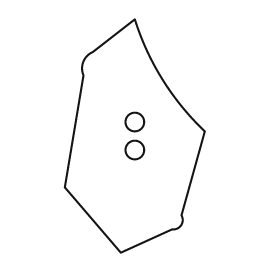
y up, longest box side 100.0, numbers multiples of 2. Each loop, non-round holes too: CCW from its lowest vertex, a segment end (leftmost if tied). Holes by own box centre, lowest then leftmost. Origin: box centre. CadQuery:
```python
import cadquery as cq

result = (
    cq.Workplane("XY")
    .moveTo(-6.0, -50.0)
    .lineTo(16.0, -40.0)
    .threePointArc((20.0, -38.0), (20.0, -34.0))
    .lineTo(30.0, 2.0)
    .threePointArc((12.0, 24.0), (0.0, 50.0))
    .lineTo(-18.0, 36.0)
    .threePointArc((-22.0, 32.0), (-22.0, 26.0))
    .lineTo(-30.0, -22.0)
    .close()
    .moveTo(0.0, -6.0)
    .circle(4.0)
    .moveTo(0.0, 6.0)
    .circle(4.0)
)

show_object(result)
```